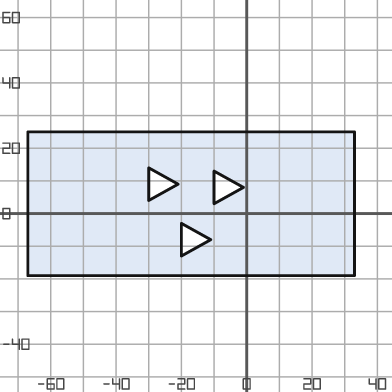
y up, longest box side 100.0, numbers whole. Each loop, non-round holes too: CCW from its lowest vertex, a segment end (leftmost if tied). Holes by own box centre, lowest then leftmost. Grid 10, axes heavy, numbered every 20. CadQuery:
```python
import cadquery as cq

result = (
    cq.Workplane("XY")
    .moveTo(-67.0, -19.0)
    .lineTo(33.0, -19.0)
    .lineTo(33.0, 25.0)
    .lineTo(-67.0, 25.0)
    .close()
    .moveTo(-20.0, -13.0)
    .lineTo(-11.0, -8.0)
    .lineTo(-20.0, -3.0)
    .close()
    .moveTo(-10.0, 3.0)
    .lineTo(-1.0, 8.0)
    .lineTo(-10.0, 13.0)
    .close()
    .moveTo(-30.0, 4.0)
    .lineTo(-21.0, 9.0)
    .lineTo(-30.0, 14.0)
    .close()
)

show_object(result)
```